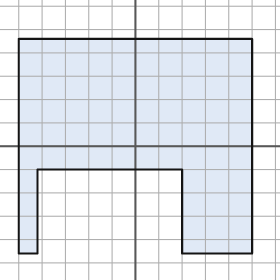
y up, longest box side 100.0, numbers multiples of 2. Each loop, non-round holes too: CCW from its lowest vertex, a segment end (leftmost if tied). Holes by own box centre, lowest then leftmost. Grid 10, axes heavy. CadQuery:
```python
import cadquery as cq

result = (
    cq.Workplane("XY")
    .moveTo(-50.0, -46.0)
    .lineTo(-42.0, -46.0)
    .lineTo(-42.0, -10.0)
    .lineTo(20.0, -10.0)
    .lineTo(20.0, -46.0)
    .lineTo(50.0, -46.0)
    .lineTo(50.0, 46.0)
    .lineTo(-50.0, 46.0)
    .close()
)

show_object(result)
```